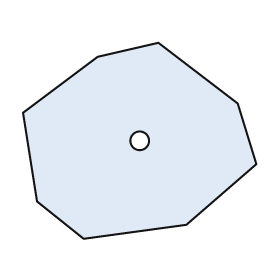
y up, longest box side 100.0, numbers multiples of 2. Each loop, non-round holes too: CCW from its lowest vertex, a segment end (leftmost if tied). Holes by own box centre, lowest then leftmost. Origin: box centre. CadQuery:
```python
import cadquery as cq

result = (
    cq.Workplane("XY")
    .moveTo(-24.0, -42.0)
    .lineTo(20.0, -36.0)
    .lineTo(50.0, -10.0)
    .lineTo(42.0, 16.0)
    .lineTo(8.0, 42.0)
    .lineTo(-18.0, 36.0)
    .lineTo(-50.0, 12.0)
    .lineTo(-44.0, -26.0)
    .close()
    .moveTo(0.0, 0.0)
    .circle(4.0)
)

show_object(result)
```